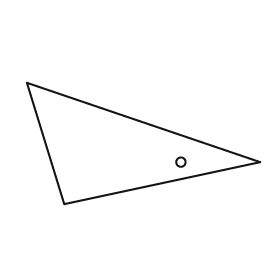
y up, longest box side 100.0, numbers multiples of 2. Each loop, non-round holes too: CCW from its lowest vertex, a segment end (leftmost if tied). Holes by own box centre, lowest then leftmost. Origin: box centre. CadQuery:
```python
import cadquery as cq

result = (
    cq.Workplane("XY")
    .moveTo(-34.0, -26.0)
    .lineTo(50.0, -8.0)
    .lineTo(-50.0, 26.0)
    .close()
    .moveTo(16.0, -8.0)
    .circle(2.0)
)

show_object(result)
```